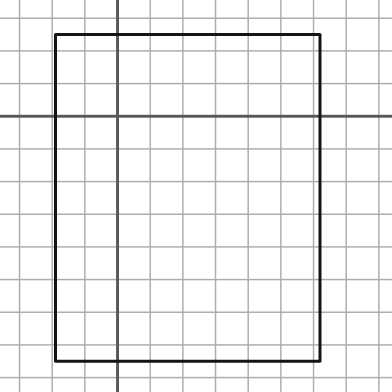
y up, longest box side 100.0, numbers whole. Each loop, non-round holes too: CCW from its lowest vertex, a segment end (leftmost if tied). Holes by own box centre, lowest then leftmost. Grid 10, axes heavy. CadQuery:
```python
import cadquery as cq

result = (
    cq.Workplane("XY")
    .moveTo(-19.0, -75.0)
    .lineTo(62.0, -75.0)
    .lineTo(62.0, 25.0)
    .lineTo(-19.0, 25.0)
    .close()
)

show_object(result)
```